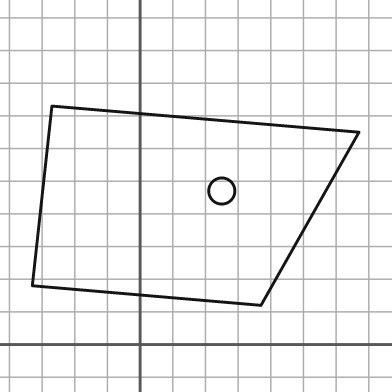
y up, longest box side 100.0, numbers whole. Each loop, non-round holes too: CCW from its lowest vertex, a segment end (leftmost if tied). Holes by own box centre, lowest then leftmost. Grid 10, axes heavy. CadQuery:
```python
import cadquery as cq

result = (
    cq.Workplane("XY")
    .moveTo(37.0, 12.0)
    .lineTo(67.0, 65.0)
    .lineTo(-27.0, 73.0)
    .lineTo(-33.0, 18.0)
    .close()
    .moveTo(25.0, 47.0)
    .circle(4.0)
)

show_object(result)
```